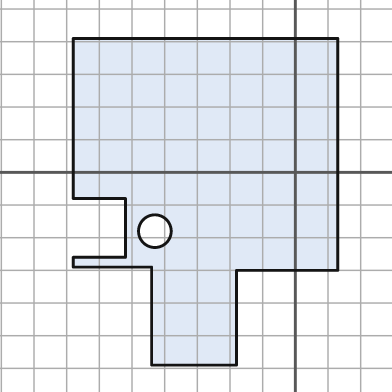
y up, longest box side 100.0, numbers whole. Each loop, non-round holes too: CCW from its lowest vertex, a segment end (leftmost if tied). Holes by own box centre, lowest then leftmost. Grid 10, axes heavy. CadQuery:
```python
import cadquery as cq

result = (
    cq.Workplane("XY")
    .moveTo(-44.0, -59.0)
    .lineTo(-18.0, -59.0)
    .lineTo(-18.0, -30.0)
    .lineTo(13.0, -30.0)
    .lineTo(13.0, 41.0)
    .lineTo(-68.0, 41.0)
    .lineTo(-68.0, -8.0)
    .lineTo(-52.0, -8.0)
    .lineTo(-52.0, -26.0)
    .lineTo(-68.0, -26.0)
    .lineTo(-68.0, -29.0)
    .lineTo(-44.0, -29.0)
    .close()
    .moveTo(-43.0, -18.0)
    .circle(5.0)
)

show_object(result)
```